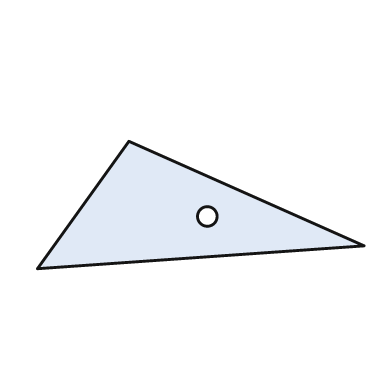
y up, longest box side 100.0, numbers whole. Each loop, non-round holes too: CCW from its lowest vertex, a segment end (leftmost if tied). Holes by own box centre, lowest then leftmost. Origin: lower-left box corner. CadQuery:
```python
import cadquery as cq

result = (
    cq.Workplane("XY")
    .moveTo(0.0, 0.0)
    .lineTo(100.0, 7.0)
    .lineTo(28.0, 39.0)
    .close()
    .moveTo(52.0, 16.0)
    .circle(3.0)
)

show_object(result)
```